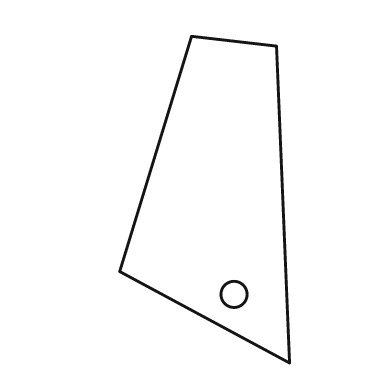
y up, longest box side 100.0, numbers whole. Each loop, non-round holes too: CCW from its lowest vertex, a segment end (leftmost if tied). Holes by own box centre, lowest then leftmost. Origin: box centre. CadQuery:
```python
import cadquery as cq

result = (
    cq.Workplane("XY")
    .moveTo(26.0, -50.0)
    .lineTo(22.0, 47.0)
    .lineTo(-4.0, 50.0)
    .lineTo(-26.0, -22.0)
    .close()
    .moveTo(9.0, -29.0)
    .circle(4.0)
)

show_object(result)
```